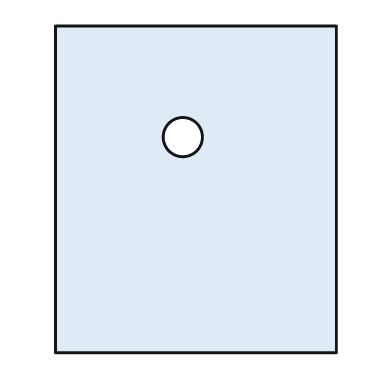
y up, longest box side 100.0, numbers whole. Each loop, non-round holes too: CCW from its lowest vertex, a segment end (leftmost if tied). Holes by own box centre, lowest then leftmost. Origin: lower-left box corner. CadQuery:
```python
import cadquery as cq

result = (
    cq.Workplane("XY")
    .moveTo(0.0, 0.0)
    .lineTo(86.0, 0.0)
    .lineTo(86.0, 100.0)
    .lineTo(0.0, 100.0)
    .close()
    .moveTo(39.0, 66.0)
    .circle(6.0)
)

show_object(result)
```